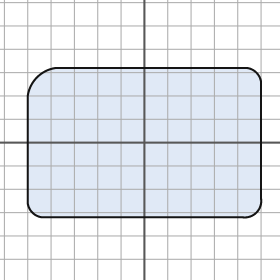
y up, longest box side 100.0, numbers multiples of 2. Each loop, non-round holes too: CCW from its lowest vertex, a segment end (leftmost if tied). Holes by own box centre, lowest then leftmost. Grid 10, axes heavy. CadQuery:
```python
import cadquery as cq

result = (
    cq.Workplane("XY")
    .moveTo(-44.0, -32.0)
    .lineTo(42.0, -32.0)
    .threePointArc((48.0, -30.0), (50.0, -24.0))
    .lineTo(50.0, 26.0)
    .threePointArc((48.0, 30.0), (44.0, 32.0))
    .lineTo(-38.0, 32.0)
    .threePointArc((-46.0, 28.0), (-50.0, 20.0))
    .lineTo(-50.0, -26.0)
    .threePointArc((-48.0, -30.0), (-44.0, -32.0))
    .close()
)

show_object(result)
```